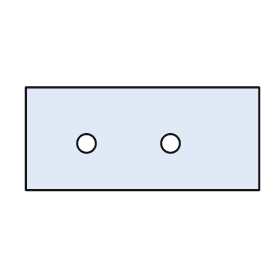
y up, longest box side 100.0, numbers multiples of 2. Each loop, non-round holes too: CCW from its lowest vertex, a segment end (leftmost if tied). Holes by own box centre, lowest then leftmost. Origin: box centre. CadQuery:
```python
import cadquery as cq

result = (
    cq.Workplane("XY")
    .moveTo(-50.0, -22.0)
    .lineTo(50.0, -22.0)
    .lineTo(50.0, 22.0)
    .lineTo(-50.0, 22.0)
    .close()
    .moveTo(-24.0, -2.0)
    .circle(4.0)
    .moveTo(12.0, -2.0)
    .circle(4.0)
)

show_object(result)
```